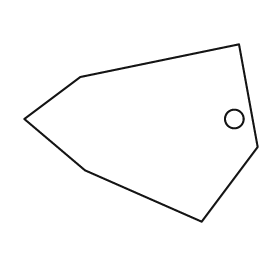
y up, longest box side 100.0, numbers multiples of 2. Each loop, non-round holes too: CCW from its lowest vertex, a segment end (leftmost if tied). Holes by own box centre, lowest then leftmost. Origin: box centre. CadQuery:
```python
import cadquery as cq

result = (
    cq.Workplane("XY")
    .moveTo(26.0, -38.0)
    .lineTo(50.0, -6.0)
    .lineTo(42.0, 38.0)
    .lineTo(-26.0, 24.0)
    .lineTo(-50.0, 6.0)
    .lineTo(-24.0, -16.0)
    .close()
    .moveTo(40.0, 6.0)
    .circle(4.0)
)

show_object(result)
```